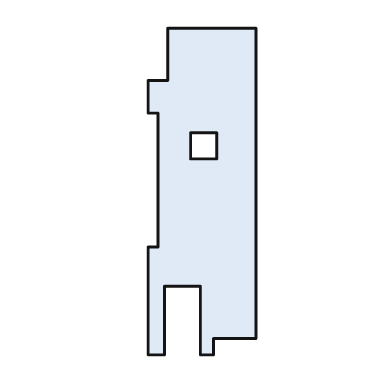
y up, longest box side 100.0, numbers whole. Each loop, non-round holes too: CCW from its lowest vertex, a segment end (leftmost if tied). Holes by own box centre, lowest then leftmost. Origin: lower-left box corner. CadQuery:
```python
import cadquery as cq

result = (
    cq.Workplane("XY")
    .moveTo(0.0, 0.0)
    .lineTo(5.0, 0.0)
    .lineTo(5.0, 21.0)
    .lineTo(16.0, 21.0)
    .lineTo(16.0, 0.0)
    .lineTo(20.0, 0.0)
    .lineTo(20.0, 5.0)
    .lineTo(33.0, 5.0)
    .lineTo(33.0, 100.0)
    .lineTo(6.0, 100.0)
    .lineTo(6.0, 84.0)
    .lineTo(0.0, 84.0)
    .lineTo(0.0, 74.0)
    .lineTo(3.0, 74.0)
    .lineTo(3.0, 33.0)
    .lineTo(0.0, 33.0)
    .close()
    .moveTo(13.0, 60.0)
    .lineTo(21.0, 60.0)
    .lineTo(21.0, 68.0)
    .lineTo(13.0, 68.0)
    .close()
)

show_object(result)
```